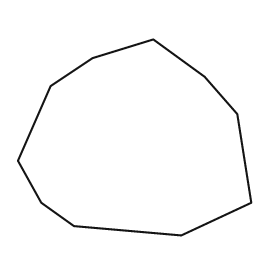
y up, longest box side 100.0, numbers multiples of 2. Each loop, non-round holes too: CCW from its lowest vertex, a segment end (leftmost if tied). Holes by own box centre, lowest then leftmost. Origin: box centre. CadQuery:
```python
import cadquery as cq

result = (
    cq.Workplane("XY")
    .moveTo(20.0, -42.0)
    .lineTo(50.0, -28.0)
    .lineTo(44.0, 10.0)
    .lineTo(30.0, 26.0)
    .lineTo(8.0, 42.0)
    .lineTo(-18.0, 34.0)
    .lineTo(-36.0, 22.0)
    .lineTo(-50.0, -10.0)
    .lineTo(-40.0, -28.0)
    .lineTo(-26.0, -38.0)
    .close()
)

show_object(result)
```